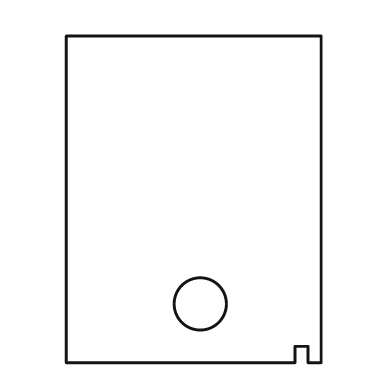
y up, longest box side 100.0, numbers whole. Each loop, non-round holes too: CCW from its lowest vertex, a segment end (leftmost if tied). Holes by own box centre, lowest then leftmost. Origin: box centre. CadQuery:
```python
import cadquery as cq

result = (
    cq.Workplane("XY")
    .moveTo(-39.0, -50.0)
    .lineTo(31.0, -50.0)
    .lineTo(31.0, -45.0)
    .lineTo(35.0, -45.0)
    .lineTo(35.0, -50.0)
    .lineTo(39.0, -50.0)
    .lineTo(39.0, 50.0)
    .lineTo(-39.0, 50.0)
    .close()
    .moveTo(2.0, -32.0)
    .circle(8.0)
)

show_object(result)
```